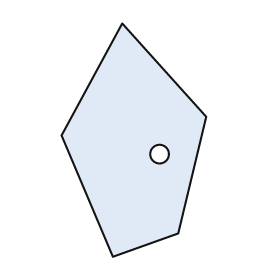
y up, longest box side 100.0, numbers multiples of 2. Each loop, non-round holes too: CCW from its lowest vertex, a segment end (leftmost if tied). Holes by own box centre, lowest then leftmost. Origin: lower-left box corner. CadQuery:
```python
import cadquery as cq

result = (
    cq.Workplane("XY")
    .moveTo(22.0, 0.0)
    .lineTo(50.0, 10.0)
    .lineTo(62.0, 60.0)
    .lineTo(26.0, 100.0)
    .lineTo(0.0, 52.0)
    .close()
    .moveTo(42.0, 44.0)
    .circle(4.0)
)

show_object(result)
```